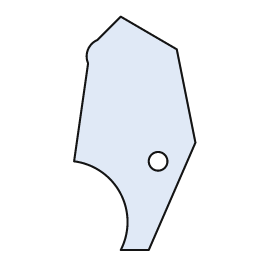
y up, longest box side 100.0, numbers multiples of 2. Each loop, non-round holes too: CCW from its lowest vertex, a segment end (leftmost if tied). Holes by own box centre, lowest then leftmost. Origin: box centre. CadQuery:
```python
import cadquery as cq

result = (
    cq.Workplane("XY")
    .moveTo(-6.0, -50.0)
    .lineTo(6.0, -50.0)
    .lineTo(26.0, -4.0)
    .lineTo(18.0, 36.0)
    .lineTo(-6.0, 50.0)
    .lineTo(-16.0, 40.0)
    .threePointArc((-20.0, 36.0), (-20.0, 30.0))
    .lineTo(-26.0, -12.0)
    .threePointArc((-6.0, -26.0), (-6.0, -50.0))
    .close()
    .moveTo(10.0, -12.0)
    .circle(4.0)
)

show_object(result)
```